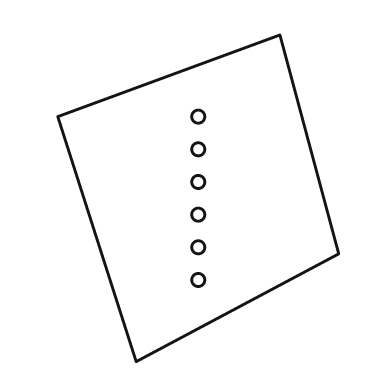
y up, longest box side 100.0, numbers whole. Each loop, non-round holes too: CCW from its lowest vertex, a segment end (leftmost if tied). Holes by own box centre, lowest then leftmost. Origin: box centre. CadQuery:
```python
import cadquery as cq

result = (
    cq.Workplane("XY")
    .moveTo(-19.0, -50.0)
    .lineTo(43.0, -17.0)
    .lineTo(25.0, 50.0)
    .lineTo(-43.0, 25.0)
    .close()
    .moveTo(0.0, -25.0)
    .circle(2.0)
    .moveTo(0.0, -15.0)
    .circle(2.0)
    .moveTo(0.0, -5.0)
    .circle(2.0)
    .moveTo(0.0, 5.0)
    .circle(2.0)
    .moveTo(0.0, 15.0)
    .circle(2.0)
    .moveTo(0.0, 25.0)
    .circle(2.0)
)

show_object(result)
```